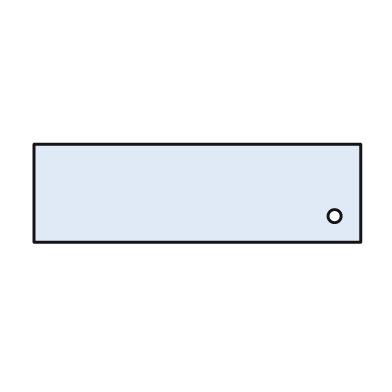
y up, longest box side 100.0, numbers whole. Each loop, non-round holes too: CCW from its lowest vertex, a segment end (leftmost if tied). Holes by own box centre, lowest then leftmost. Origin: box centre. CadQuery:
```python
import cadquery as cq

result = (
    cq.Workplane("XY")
    .moveTo(-50.0, -15.0)
    .lineTo(50.0, -15.0)
    .lineTo(50.0, 15.0)
    .lineTo(-50.0, 15.0)
    .close()
    .moveTo(42.0, -7.0)
    .circle(2.0)
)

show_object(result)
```